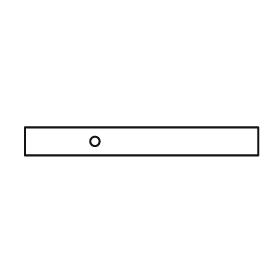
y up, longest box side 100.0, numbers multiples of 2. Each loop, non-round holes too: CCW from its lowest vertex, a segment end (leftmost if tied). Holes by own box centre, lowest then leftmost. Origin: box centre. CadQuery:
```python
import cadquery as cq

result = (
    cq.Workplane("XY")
    .moveTo(-50.0, -6.0)
    .lineTo(50.0, -6.0)
    .lineTo(50.0, 6.0)
    .lineTo(-50.0, 6.0)
    .close()
    .moveTo(-20.0, 0.0)
    .circle(2.0)
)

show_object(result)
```